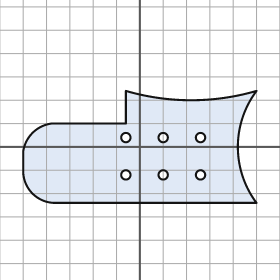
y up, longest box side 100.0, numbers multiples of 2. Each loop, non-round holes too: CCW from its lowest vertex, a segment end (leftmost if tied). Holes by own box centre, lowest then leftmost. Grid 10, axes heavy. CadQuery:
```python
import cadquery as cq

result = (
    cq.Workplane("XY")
    .moveTo(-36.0, -24.0)
    .lineTo(50.0, -24.0)
    .threePointArc((42.0, 0.0), (50.0, 24.0))
    .threePointArc((22.0, 20.0), (-6.0, 24.0))
    .lineTo(-6.0, 10.0)
    .lineTo(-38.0, 10.0)
    .threePointArc((-46.0, 6.0), (-50.0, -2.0))
    .lineTo(-50.0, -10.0)
    .threePointArc((-46.0, -20.0), (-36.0, -24.0))
    .close()
    .moveTo(-6.0, -12.0)
    .circle(2.0)
    .moveTo(10.0, -12.0)
    .circle(2.0)
    .moveTo(26.0, -12.0)
    .circle(2.0)
    .moveTo(-6.0, 4.0)
    .circle(2.0)
    .moveTo(10.0, 4.0)
    .circle(2.0)
    .moveTo(26.0, 4.0)
    .circle(2.0)
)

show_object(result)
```